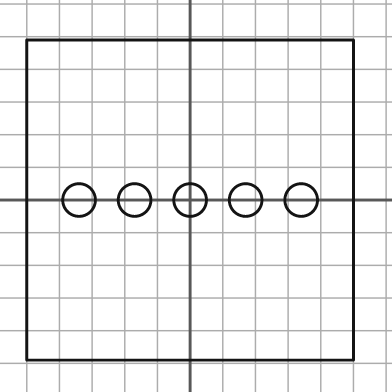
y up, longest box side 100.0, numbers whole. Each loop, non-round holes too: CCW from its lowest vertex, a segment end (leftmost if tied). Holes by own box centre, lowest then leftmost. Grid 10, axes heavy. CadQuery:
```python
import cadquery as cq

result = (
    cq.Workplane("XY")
    .moveTo(-50.0, -49.0)
    .lineTo(50.0, -49.0)
    .lineTo(50.0, 49.0)
    .lineTo(-50.0, 49.0)
    .close()
    .moveTo(-34.0, 0.0)
    .circle(5.0)
    .moveTo(-17.0, 0.0)
    .circle(5.0)
    .moveTo(0.0, 0.0)
    .circle(5.0)
    .moveTo(17.0, 0.0)
    .circle(5.0)
    .moveTo(34.0, 0.0)
    .circle(5.0)
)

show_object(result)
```